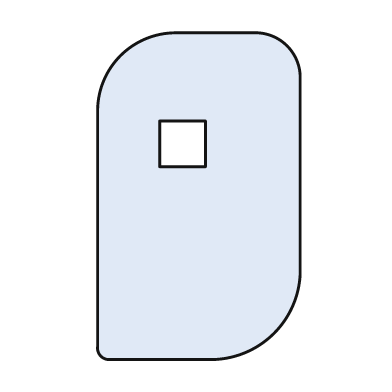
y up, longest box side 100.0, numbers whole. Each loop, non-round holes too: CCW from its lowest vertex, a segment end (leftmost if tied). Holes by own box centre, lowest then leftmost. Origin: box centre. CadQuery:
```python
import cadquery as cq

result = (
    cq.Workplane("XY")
    .moveTo(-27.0, -50.0)
    .lineTo(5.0, -50.0)
    .threePointArc((23.0, -42.0), (31.0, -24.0))
    .lineTo(31.0, 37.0)
    .threePointArc((27.0, 46.0), (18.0, 50.0))
    .lineTo(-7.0, 50.0)
    .threePointArc((-24.0, 43.0), (-31.0, 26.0))
    .lineTo(-31.0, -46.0)
    .threePointArc((-30.0, -49.0), (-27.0, -50.0))
    .close()
    .moveTo(-12.0, 9.0)
    .lineTo(2.0, 9.0)
    .lineTo(2.0, 23.0)
    .lineTo(-12.0, 23.0)
    .close()
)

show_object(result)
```